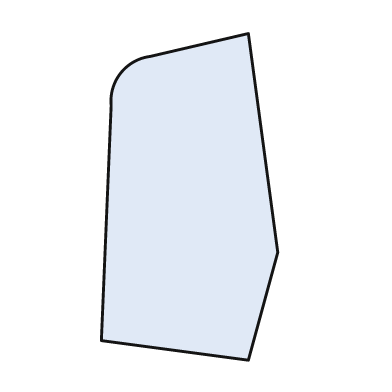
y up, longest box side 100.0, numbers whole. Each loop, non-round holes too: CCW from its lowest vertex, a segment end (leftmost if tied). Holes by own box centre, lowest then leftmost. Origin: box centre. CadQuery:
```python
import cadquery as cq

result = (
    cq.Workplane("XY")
    .moveTo(18.0, -50.0)
    .lineTo(27.0, -17.0)
    .lineTo(18.0, 50.0)
    .lineTo(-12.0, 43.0)
    .threePointArc((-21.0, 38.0), (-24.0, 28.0))
    .lineTo(-27.0, -44.0)
    .close()
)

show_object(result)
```